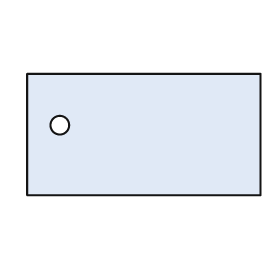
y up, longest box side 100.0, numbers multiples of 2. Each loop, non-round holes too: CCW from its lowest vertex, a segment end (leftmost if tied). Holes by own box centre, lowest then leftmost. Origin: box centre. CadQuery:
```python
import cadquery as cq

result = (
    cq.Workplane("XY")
    .moveTo(-50.0, -26.0)
    .lineTo(50.0, -26.0)
    .lineTo(50.0, 26.0)
    .lineTo(-50.0, 26.0)
    .close()
    .moveTo(-36.0, 4.0)
    .circle(4.0)
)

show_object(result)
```